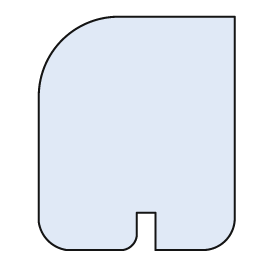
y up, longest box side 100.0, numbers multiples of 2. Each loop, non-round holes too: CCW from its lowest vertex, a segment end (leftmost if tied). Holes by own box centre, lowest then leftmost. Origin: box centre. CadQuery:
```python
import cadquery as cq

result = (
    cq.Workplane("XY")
    .moveTo(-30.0, -50.0)
    .lineTo(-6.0, -50.0)
    .threePointArc((-2.0, -48.0), (0.0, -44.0))
    .lineTo(0.0, -34.0)
    .lineTo(8.0, -34.0)
    .lineTo(8.0, -50.0)
    .lineTo(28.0, -50.0)
    .threePointArc((38.0, -46.0), (42.0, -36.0))
    .lineTo(42.0, 50.0)
    .lineTo(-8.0, 50.0)
    .threePointArc((-32.0, 40.0), (-42.0, 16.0))
    .lineTo(-42.0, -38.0)
    .threePointArc((-38.0, -46.0), (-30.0, -50.0))
    .close()
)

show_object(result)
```